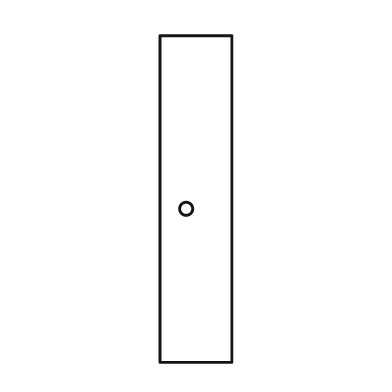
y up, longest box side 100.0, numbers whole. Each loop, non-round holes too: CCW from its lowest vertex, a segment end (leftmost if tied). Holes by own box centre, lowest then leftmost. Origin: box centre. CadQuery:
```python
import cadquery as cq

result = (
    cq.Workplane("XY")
    .moveTo(-11.0, -50.0)
    .lineTo(11.0, -50.0)
    .lineTo(11.0, 50.0)
    .lineTo(-11.0, 50.0)
    .close()
    .moveTo(-3.0, -3.0)
    .circle(2.0)
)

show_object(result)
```